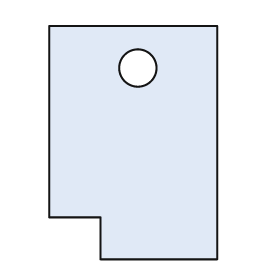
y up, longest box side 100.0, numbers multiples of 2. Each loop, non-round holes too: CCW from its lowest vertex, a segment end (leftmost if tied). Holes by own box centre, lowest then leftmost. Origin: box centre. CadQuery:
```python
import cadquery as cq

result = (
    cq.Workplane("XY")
    .moveTo(-14.0, -50.0)
    .lineTo(36.0, -50.0)
    .lineTo(36.0, 50.0)
    .lineTo(-36.0, 50.0)
    .lineTo(-36.0, -32.0)
    .lineTo(-14.0, -32.0)
    .close()
    .moveTo(2.0, 32.0)
    .circle(8.0)
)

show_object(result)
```